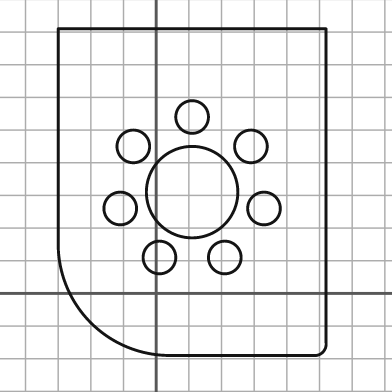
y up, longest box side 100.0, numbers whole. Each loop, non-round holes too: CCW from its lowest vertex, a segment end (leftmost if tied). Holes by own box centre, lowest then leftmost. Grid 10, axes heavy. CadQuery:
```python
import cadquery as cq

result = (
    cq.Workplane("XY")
    .moveTo(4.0, -19.0)
    .lineTo(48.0, -19.0)
    .threePointArc((51.0, -18.0), (52.0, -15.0))
    .lineTo(52.0, 81.0)
    .lineTo(-30.0, 81.0)
    .lineTo(-30.0, 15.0)
    .threePointArc((-20.0, -9.0), (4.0, -19.0))
    .close()
    .moveTo(1.0, 11.0)
    .circle(5.0)
    .moveTo(21.0, 11.0)
    .circle(5.0)
    .moveTo(-11.0, 26.0)
    .circle(5.0)
    .moveTo(33.0, 26.0)
    .circle(5.0)
    .moveTo(11.0, 31.0)
    .circle(14.0)
    .moveTo(-7.0, 45.0)
    .circle(5.0)
    .moveTo(29.0, 45.0)
    .circle(5.0)
    .moveTo(11.0, 54.0)
    .circle(5.0)
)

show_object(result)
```